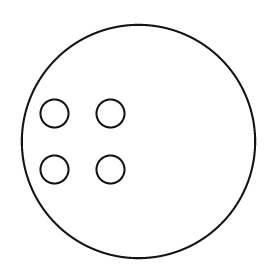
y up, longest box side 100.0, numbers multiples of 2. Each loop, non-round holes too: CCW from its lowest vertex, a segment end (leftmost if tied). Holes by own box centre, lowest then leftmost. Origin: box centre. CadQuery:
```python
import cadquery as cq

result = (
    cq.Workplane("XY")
    .moveTo(0.0, 0.0)
    .circle(50.0)
    .moveTo(-36.0, -12.0)
    .circle(6.0)
    .moveTo(-12.0, -12.0)
    .circle(6.0)
    .moveTo(-36.0, 12.0)
    .circle(6.0)
    .moveTo(-12.0, 12.0)
    .circle(6.0)
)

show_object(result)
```